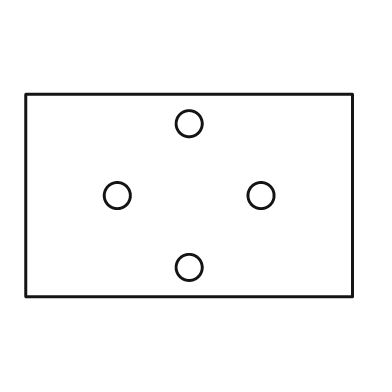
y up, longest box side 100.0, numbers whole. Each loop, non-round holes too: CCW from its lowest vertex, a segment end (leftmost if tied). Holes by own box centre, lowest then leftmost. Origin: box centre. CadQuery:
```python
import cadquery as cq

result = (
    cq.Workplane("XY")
    .moveTo(-50.0, -31.0)
    .lineTo(50.0, -31.0)
    .lineTo(50.0, 31.0)
    .lineTo(-50.0, 31.0)
    .close()
    .moveTo(0.0, -22.0)
    .circle(4.0)
    .moveTo(-22.0, 0.0)
    .circle(4.0)
    .moveTo(22.0, 0.0)
    .circle(4.0)
    .moveTo(0.0, 22.0)
    .circle(4.0)
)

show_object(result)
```